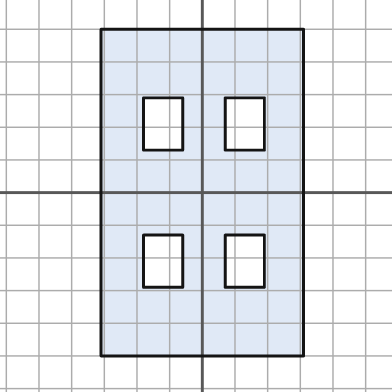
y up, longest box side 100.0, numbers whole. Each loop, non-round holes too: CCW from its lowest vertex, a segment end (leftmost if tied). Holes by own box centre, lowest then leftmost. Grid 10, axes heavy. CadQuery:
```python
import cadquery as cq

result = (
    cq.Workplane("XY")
    .moveTo(-31.0, -50.0)
    .lineTo(31.0, -50.0)
    .lineTo(31.0, 50.0)
    .lineTo(-31.0, 50.0)
    .close()
    .moveTo(-18.0, -29.0)
    .lineTo(-6.0, -29.0)
    .lineTo(-6.0, -13.0)
    .lineTo(-18.0, -13.0)
    .close()
    .moveTo(7.0, -29.0)
    .lineTo(19.0, -29.0)
    .lineTo(19.0, -13.0)
    .lineTo(7.0, -13.0)
    .close()
    .moveTo(-18.0, 13.0)
    .lineTo(-6.0, 13.0)
    .lineTo(-6.0, 29.0)
    .lineTo(-18.0, 29.0)
    .close()
    .moveTo(7.0, 13.0)
    .lineTo(19.0, 13.0)
    .lineTo(19.0, 29.0)
    .lineTo(7.0, 29.0)
    .close()
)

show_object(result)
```